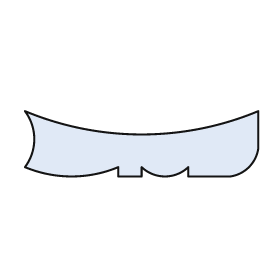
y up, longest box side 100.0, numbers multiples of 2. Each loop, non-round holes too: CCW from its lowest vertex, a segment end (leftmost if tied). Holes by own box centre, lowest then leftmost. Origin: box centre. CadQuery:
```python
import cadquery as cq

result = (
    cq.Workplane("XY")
    .moveTo(-10.0, -14.0)
    .lineTo(0.0, -14.0)
    .lineTo(0.0, -10.0)
    .threePointArc((10.0, -14.0), (20.0, -10.0))
    .lineTo(20.0, -14.0)
    .lineTo(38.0, -14.0)
    .threePointArc((46.0, -10.0), (50.0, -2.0))
    .lineTo(50.0, 14.0)
    .threePointArc((0.0, 4.0), (-50.0, 14.0))
    .threePointArc((-46.0, 2.0), (-50.0, -10.0))
    .threePointArc((-30.0, -14.0), (-10.0, -10.0))
    .close()
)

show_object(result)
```